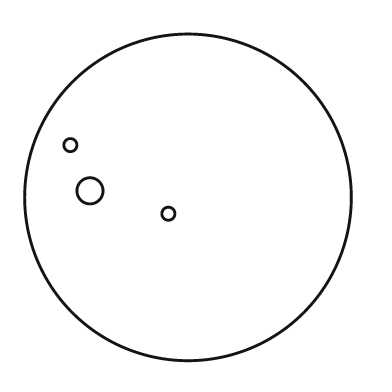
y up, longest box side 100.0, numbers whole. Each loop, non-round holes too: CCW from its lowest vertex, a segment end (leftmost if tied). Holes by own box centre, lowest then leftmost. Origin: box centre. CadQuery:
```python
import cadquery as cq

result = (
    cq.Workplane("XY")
    .moveTo(0.0, 0.0)
    .circle(50.0)
    .moveTo(-6.0, -5.0)
    .circle(2.0)
    .moveTo(-30.0, 2.0)
    .circle(4.0)
    .moveTo(-36.0, 16.0)
    .circle(2.0)
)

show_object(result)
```